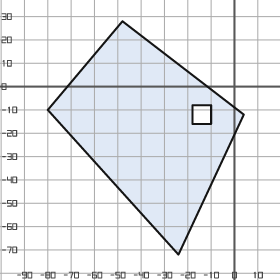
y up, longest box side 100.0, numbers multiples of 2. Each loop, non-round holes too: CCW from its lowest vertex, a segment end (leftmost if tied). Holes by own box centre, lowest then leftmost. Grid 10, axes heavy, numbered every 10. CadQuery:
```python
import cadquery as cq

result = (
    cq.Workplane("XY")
    .moveTo(-24.0, -72.0)
    .lineTo(4.0, -12.0)
    .lineTo(-48.0, 28.0)
    .lineTo(-80.0, -10.0)
    .close()
    .moveTo(-18.0, -16.0)
    .lineTo(-10.0, -16.0)
    .lineTo(-10.0, -8.0)
    .lineTo(-18.0, -8.0)
    .close()
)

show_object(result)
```